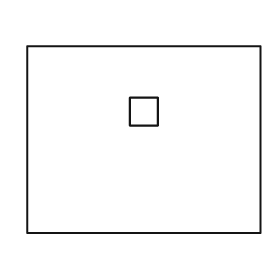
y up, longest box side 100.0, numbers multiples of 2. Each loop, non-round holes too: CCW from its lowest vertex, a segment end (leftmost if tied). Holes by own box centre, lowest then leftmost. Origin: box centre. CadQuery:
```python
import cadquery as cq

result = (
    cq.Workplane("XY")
    .moveTo(-50.0, -40.0)
    .lineTo(50.0, -40.0)
    .lineTo(50.0, 40.0)
    .lineTo(-50.0, 40.0)
    .close()
    .moveTo(-6.0, 6.0)
    .lineTo(6.0, 6.0)
    .lineTo(6.0, 18.0)
    .lineTo(-6.0, 18.0)
    .close()
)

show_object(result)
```